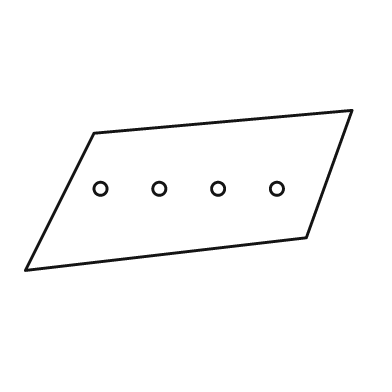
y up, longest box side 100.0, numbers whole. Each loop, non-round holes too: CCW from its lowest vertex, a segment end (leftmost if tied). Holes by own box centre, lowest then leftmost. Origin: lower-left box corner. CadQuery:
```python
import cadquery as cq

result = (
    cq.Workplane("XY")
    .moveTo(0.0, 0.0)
    .lineTo(86.0, 10.0)
    .lineTo(100.0, 49.0)
    .lineTo(21.0, 42.0)
    .close()
    .moveTo(23.0, 25.0)
    .circle(2.0)
    .moveTo(41.0, 25.0)
    .circle(2.0)
    .moveTo(59.0, 25.0)
    .circle(2.0)
    .moveTo(77.0, 25.0)
    .circle(2.0)
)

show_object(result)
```